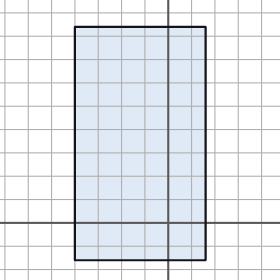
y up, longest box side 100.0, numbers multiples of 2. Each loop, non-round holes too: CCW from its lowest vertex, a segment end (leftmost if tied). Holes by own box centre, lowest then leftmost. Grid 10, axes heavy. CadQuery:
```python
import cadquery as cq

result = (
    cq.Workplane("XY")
    .moveTo(-40.0, -16.0)
    .lineTo(16.0, -16.0)
    .lineTo(16.0, 84.0)
    .lineTo(-40.0, 84.0)
    .close()
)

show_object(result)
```